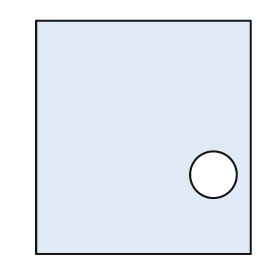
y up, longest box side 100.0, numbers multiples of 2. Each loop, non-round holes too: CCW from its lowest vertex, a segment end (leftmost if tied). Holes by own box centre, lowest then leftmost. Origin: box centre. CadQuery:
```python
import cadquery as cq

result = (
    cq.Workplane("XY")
    .moveTo(-46.0, -50.0)
    .lineTo(46.0, -50.0)
    .lineTo(46.0, 50.0)
    .lineTo(-46.0, 50.0)
    .close()
    .moveTo(30.0, -16.0)
    .circle(10.0)
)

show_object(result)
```